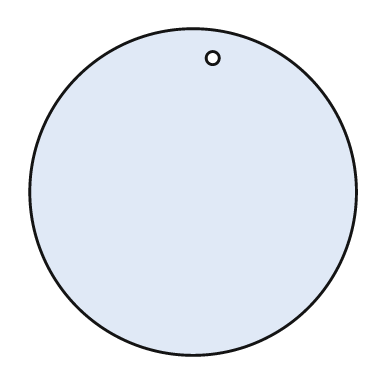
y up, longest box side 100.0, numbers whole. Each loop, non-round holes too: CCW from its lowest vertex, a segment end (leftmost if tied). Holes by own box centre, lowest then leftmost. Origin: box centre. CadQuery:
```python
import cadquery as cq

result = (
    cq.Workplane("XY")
    .moveTo(0.0, 0.0)
    .circle(50.0)
    .moveTo(6.0, 41.0)
    .circle(2.0)
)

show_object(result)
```